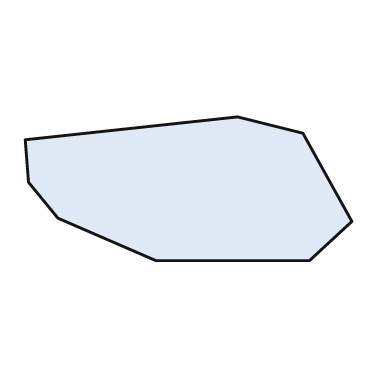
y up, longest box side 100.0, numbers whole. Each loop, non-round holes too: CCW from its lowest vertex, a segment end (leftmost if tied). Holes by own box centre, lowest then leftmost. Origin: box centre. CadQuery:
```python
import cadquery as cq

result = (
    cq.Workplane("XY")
    .moveTo(-10.0, -22.0)
    .lineTo(37.0, -22.0)
    .lineTo(50.0, -10.0)
    .lineTo(35.0, 17.0)
    .lineTo(15.0, 22.0)
    .lineTo(-50.0, 15.0)
    .lineTo(-49.0, 2.0)
    .lineTo(-40.0, -9.0)
    .close()
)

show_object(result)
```